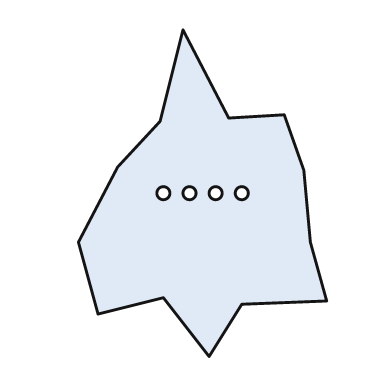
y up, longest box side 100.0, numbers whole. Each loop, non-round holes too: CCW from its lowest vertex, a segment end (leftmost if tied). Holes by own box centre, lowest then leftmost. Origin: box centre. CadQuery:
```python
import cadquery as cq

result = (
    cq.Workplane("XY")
    .moveTo(2.0, -50.0)
    .lineTo(12.0, -34.0)
    .lineTo(38.0, -33.0)
    .lineTo(33.0, -15.0)
    .lineTo(31.0, 7.0)
    .lineTo(25.0, 24.0)
    .lineTo(8.0, 23.0)
    .lineTo(-6.0, 50.0)
    .lineTo(-13.0, 22.0)
    .lineTo(-26.0, 8.0)
    .lineTo(-38.0, -15.0)
    .lineTo(-32.0, -37.0)
    .lineTo(-12.0, -32.0)
    .close()
    .moveTo(-12.0, 0.0)
    .circle(2.0)
    .moveTo(-4.0, 0.0)
    .circle(2.0)
    .moveTo(4.0, 0.0)
    .circle(2.0)
    .moveTo(12.0, 0.0)
    .circle(2.0)
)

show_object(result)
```